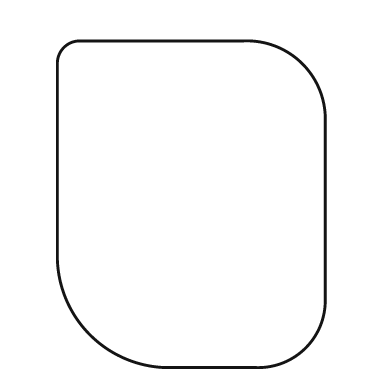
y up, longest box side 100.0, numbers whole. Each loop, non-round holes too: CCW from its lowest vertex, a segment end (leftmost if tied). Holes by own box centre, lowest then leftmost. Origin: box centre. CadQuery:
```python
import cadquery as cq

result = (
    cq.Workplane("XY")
    .moveTo(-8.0, -50.0)
    .lineTo(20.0, -50.0)
    .threePointArc((35.0, -44.0), (41.0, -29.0))
    .lineTo(41.0, 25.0)
    .threePointArc((34.0, 43.0), (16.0, 50.0))
    .lineTo(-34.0, 50.0)
    .threePointArc((-39.0, 48.0), (-41.0, 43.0))
    .lineTo(-41.0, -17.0)
    .threePointArc((-31.0, -40.0), (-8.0, -50.0))
    .close()
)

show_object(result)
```